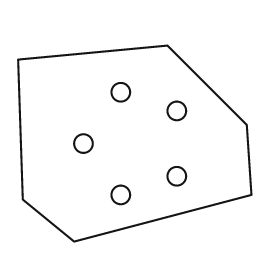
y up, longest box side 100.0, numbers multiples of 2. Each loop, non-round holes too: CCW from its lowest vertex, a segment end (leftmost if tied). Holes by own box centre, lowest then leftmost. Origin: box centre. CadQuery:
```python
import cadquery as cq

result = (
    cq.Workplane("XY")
    .moveTo(-26.0, -42.0)
    .lineTo(50.0, -22.0)
    .lineTo(48.0, 8.0)
    .lineTo(14.0, 42.0)
    .lineTo(-50.0, 36.0)
    .lineTo(-48.0, -24.0)
    .close()
    .moveTo(-6.0, -22.0)
    .circle(4.0)
    .moveTo(18.0, -14.0)
    .circle(4.0)
    .moveTo(-22.0, 0.0)
    .circle(4.0)
    .moveTo(18.0, 14.0)
    .circle(4.0)
    .moveTo(-6.0, 22.0)
    .circle(4.0)
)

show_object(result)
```